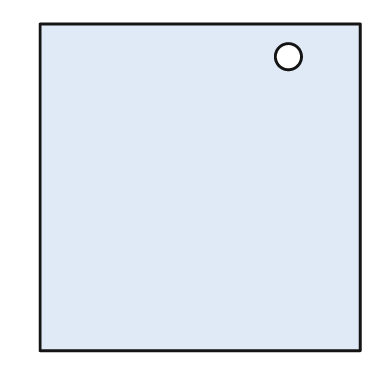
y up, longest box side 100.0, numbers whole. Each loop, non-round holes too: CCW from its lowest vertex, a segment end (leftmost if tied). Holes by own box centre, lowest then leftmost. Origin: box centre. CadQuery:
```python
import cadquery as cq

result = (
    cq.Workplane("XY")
    .moveTo(-49.0, -50.0)
    .lineTo(49.0, -50.0)
    .lineTo(49.0, 50.0)
    .lineTo(-49.0, 50.0)
    .close()
    .moveTo(27.0, 40.0)
    .circle(4.0)
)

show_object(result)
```